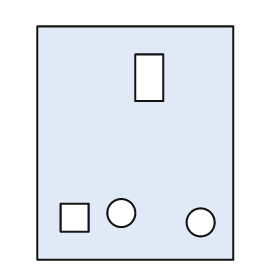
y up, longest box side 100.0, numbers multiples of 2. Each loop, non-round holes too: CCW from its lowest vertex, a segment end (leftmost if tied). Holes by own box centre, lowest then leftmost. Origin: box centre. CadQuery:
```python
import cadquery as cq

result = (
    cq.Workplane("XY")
    .moveTo(-42.0, -50.0)
    .lineTo(42.0, -50.0)
    .lineTo(42.0, 50.0)
    .lineTo(-42.0, 50.0)
    .close()
    .moveTo(28.0, -34.0)
    .circle(6.0)
    .moveTo(-32.0, -38.0)
    .lineTo(-20.0, -38.0)
    .lineTo(-20.0, -26.0)
    .lineTo(-32.0, -26.0)
    .close()
    .moveTo(-6.0, -30.0)
    .circle(6.0)
    .moveTo(0.0, 18.0)
    .lineTo(12.0, 18.0)
    .lineTo(12.0, 38.0)
    .lineTo(0.0, 38.0)
    .close()
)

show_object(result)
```